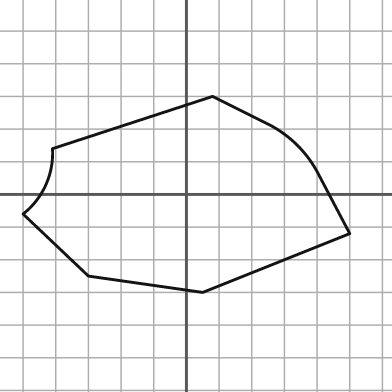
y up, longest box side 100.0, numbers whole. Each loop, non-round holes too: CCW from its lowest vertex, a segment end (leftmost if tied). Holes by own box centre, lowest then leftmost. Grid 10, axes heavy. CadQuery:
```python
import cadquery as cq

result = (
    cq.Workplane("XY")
    .moveTo(5.0, -30.0)
    .lineTo(50.0, -12.0)
    .lineTo(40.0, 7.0)
    .threePointArc((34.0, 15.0), (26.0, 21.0))
    .lineTo(8.0, 30.0)
    .lineTo(-41.0, 14.0)
    .threePointArc((-43.0, 3.0), (-50.0, -6.0))
    .lineTo(-30.0, -25.0)
    .close()
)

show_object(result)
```